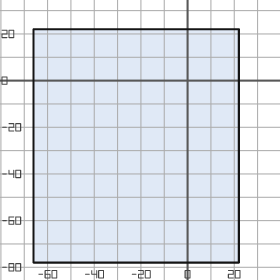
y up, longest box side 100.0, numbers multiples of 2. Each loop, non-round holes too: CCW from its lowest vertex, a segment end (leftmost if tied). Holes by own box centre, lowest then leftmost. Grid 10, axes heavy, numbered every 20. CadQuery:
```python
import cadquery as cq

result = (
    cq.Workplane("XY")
    .moveTo(-66.0, -78.0)
    .lineTo(22.0, -78.0)
    .lineTo(22.0, 22.0)
    .lineTo(-66.0, 22.0)
    .close()
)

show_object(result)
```